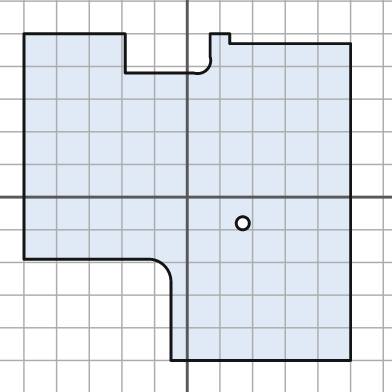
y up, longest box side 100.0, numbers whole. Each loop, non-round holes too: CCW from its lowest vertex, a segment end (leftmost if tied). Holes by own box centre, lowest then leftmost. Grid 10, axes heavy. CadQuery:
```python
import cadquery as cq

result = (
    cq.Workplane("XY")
    .moveTo(-5.0, -50.0)
    .lineTo(50.0, -50.0)
    .lineTo(50.0, 47.0)
    .lineTo(13.0, 47.0)
    .lineTo(13.0, 50.0)
    .lineTo(7.0, 50.0)
    .lineTo(7.0, 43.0)
    .threePointArc((6.0, 39.0), (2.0, 38.0))
    .lineTo(-19.0, 38.0)
    .lineTo(-19.0, 50.0)
    .lineTo(-50.0, 50.0)
    .lineTo(-50.0, -19.0)
    .lineTo(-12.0, -19.0)
    .threePointArc((-7.0, -21.0), (-5.0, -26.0))
    .close()
    .moveTo(17.0, -8.0)
    .circle(2.0)
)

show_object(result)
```